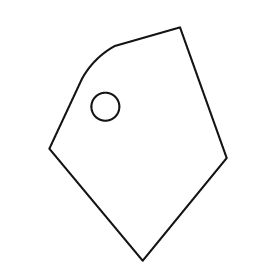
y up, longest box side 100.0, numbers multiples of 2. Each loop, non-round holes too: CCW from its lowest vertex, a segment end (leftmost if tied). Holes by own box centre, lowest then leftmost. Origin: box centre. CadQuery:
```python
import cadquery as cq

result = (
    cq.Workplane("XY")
    .moveTo(2.0, -50.0)
    .lineTo(38.0, -6.0)
    .lineTo(18.0, 50.0)
    .lineTo(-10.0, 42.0)
    .threePointArc((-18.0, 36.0), (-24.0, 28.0))
    .lineTo(-38.0, -2.0)
    .close()
    .moveTo(-14.0, 16.0)
    .circle(6.0)
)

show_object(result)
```